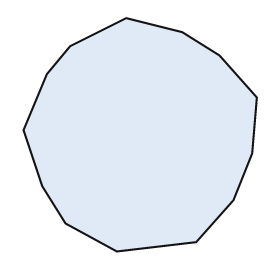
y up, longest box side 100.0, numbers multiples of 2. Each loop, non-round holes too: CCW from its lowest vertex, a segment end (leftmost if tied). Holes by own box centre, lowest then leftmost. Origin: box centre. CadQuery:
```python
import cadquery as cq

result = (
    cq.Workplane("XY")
    .moveTo(-10.0, -50.0)
    .lineTo(24.0, -46.0)
    .lineTo(40.0, -28.0)
    .lineTo(48.0, -8.0)
    .lineTo(50.0, 16.0)
    .lineTo(34.0, 34.0)
    .lineTo(18.0, 44.0)
    .lineTo(-6.0, 50.0)
    .lineTo(-30.0, 38.0)
    .lineTo(-40.0, 26.0)
    .lineTo(-50.0, 2.0)
    .lineTo(-42.0, -22.0)
    .lineTo(-32.0, -38.0)
    .close()
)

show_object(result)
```